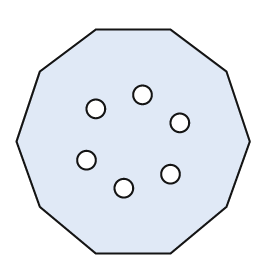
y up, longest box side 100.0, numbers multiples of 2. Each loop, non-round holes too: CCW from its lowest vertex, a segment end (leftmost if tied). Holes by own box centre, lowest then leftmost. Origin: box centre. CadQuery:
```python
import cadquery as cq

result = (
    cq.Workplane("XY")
    .moveTo(-16.0, -48.0)
    .lineTo(16.0, -48.0)
    .lineTo(40.0, -28.0)
    .lineTo(50.0, 0.0)
    .lineTo(40.0, 30.0)
    .lineTo(16.0, 48.0)
    .lineTo(-16.0, 48.0)
    .lineTo(-40.0, 30.0)
    .lineTo(-50.0, 0.0)
    .lineTo(-40.0, -28.0)
    .close()
    .moveTo(-4.0, -20.0)
    .circle(4.0)
    .moveTo(16.0, -14.0)
    .circle(4.0)
    .moveTo(-20.0, -8.0)
    .circle(4.0)
    .moveTo(20.0, 8.0)
    .circle(4.0)
    .moveTo(-16.0, 14.0)
    .circle(4.0)
    .moveTo(4.0, 20.0)
    .circle(4.0)
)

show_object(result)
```